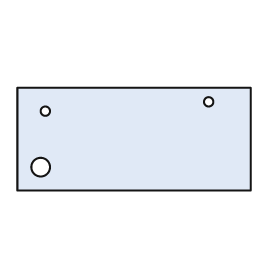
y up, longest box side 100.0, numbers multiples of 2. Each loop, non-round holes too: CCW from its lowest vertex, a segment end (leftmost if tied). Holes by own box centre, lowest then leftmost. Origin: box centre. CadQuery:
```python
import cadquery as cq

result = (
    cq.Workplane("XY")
    .moveTo(-50.0, -22.0)
    .lineTo(50.0, -22.0)
    .lineTo(50.0, 22.0)
    .lineTo(-50.0, 22.0)
    .close()
    .moveTo(-40.0, -12.0)
    .circle(4.0)
    .moveTo(-38.0, 12.0)
    .circle(2.0)
    .moveTo(32.0, 16.0)
    .circle(2.0)
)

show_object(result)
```